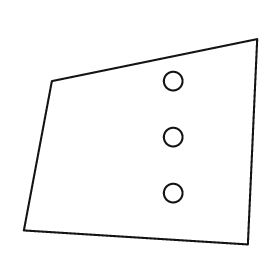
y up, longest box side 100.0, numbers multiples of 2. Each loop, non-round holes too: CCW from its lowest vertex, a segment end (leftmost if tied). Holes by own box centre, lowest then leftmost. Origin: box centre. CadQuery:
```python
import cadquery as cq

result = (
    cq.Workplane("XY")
    .moveTo(46.0, -44.0)
    .lineTo(50.0, 44.0)
    .lineTo(-38.0, 26.0)
    .lineTo(-50.0, -38.0)
    .close()
    .moveTo(14.0, -22.0)
    .circle(4.0)
    .moveTo(14.0, 2.0)
    .circle(4.0)
    .moveTo(14.0, 26.0)
    .circle(4.0)
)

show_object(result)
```